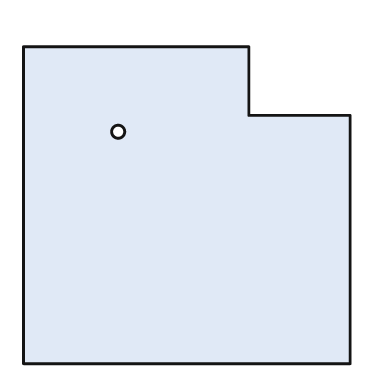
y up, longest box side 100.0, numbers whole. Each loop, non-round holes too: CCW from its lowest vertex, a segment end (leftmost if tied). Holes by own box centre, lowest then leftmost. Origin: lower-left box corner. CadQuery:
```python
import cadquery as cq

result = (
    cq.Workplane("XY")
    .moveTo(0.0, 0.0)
    .lineTo(100.0, 0.0)
    .lineTo(100.0, 76.0)
    .lineTo(69.0, 76.0)
    .lineTo(69.0, 97.0)
    .lineTo(0.0, 97.0)
    .close()
    .moveTo(29.0, 71.0)
    .circle(2.0)
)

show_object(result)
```